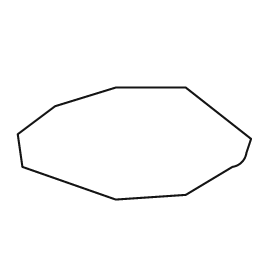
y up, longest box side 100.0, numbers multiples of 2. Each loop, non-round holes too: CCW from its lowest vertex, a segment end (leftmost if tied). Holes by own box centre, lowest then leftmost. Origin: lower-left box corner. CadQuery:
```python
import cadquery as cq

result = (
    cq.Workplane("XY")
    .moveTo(42.0, 0.0)
    .lineTo(72.0, 2.0)
    .lineTo(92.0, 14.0)
    .threePointArc((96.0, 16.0), (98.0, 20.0))
    .lineTo(100.0, 26.0)
    .lineTo(72.0, 48.0)
    .lineTo(42.0, 48.0)
    .lineTo(16.0, 40.0)
    .lineTo(0.0, 28.0)
    .lineTo(2.0, 14.0)
    .close()
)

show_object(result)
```